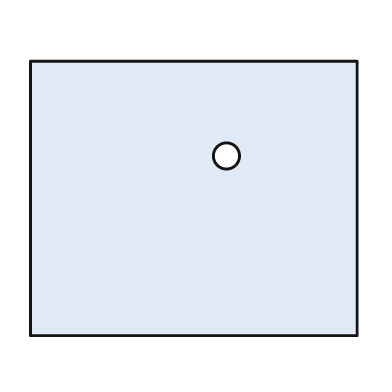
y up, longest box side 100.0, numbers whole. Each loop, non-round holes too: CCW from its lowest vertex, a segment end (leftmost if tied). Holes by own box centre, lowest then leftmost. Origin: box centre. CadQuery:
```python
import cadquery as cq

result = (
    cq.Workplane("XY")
    .moveTo(-50.0, -42.0)
    .lineTo(50.0, -42.0)
    .lineTo(50.0, 42.0)
    .lineTo(-50.0, 42.0)
    .close()
    .moveTo(10.0, 13.0)
    .circle(4.0)
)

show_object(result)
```